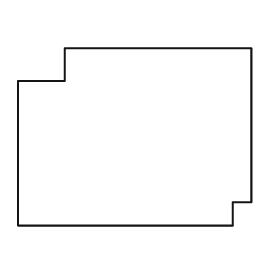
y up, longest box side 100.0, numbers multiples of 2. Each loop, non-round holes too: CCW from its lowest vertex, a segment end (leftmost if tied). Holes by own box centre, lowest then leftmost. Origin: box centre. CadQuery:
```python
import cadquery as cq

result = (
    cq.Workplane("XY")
    .moveTo(-50.0, -38.0)
    .lineTo(42.0, -38.0)
    .lineTo(42.0, -28.0)
    .lineTo(50.0, -28.0)
    .lineTo(50.0, 38.0)
    .lineTo(-30.0, 38.0)
    .lineTo(-30.0, 24.0)
    .lineTo(-50.0, 24.0)
    .close()
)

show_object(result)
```